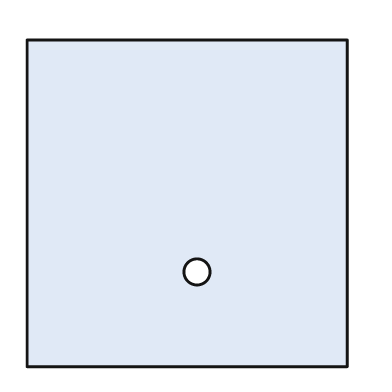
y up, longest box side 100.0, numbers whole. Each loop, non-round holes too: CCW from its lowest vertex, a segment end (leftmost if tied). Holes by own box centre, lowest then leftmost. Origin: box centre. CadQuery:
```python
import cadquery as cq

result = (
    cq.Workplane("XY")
    .moveTo(-49.0, -50.0)
    .lineTo(49.0, -50.0)
    .lineTo(49.0, 50.0)
    .lineTo(-49.0, 50.0)
    .close()
    .moveTo(3.0, -21.0)
    .circle(4.0)
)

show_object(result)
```